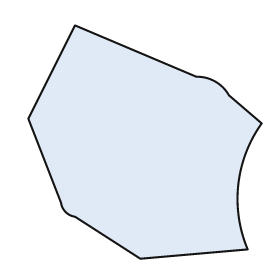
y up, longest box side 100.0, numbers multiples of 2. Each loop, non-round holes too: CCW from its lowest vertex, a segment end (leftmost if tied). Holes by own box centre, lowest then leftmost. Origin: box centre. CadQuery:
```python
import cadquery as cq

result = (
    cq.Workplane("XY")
    .moveTo(-2.0, -50.0)
    .lineTo(44.0, -46.0)
    .threePointArc((40.0, -18.0), (50.0, 8.0))
    .lineTo(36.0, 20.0)
    .threePointArc((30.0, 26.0), (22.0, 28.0))
    .lineTo(-30.0, 50.0)
    .lineTo(-50.0, 10.0)
    .lineTo(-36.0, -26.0)
    .threePointArc((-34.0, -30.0), (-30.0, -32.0))
    .close()
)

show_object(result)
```